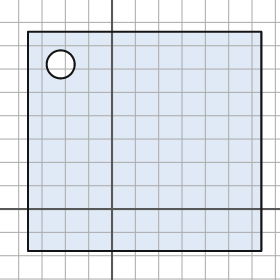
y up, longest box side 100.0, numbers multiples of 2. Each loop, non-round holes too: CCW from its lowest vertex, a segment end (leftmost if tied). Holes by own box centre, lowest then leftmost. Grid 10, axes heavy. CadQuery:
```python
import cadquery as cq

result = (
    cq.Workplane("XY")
    .moveTo(-36.0, -18.0)
    .lineTo(64.0, -18.0)
    .lineTo(64.0, 76.0)
    .lineTo(-36.0, 76.0)
    .close()
    .moveTo(-22.0, 62.0)
    .circle(6.0)
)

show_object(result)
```